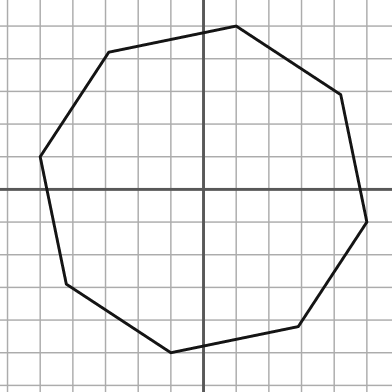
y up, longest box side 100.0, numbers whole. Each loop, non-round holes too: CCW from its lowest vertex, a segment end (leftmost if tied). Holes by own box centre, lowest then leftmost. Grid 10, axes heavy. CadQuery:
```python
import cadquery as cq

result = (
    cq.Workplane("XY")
    .moveTo(-10.0, -50.0)
    .lineTo(29.0, -42.0)
    .lineTo(50.0, -10.0)
    .lineTo(42.0, 29.0)
    .lineTo(10.0, 50.0)
    .lineTo(-29.0, 42.0)
    .lineTo(-50.0, 10.0)
    .lineTo(-42.0, -29.0)
    .close()
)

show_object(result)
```